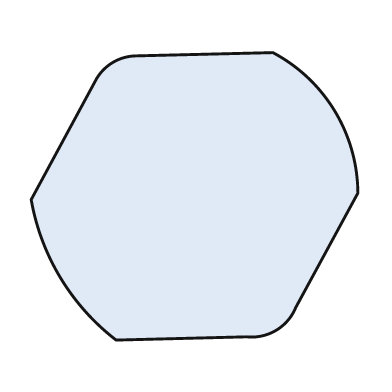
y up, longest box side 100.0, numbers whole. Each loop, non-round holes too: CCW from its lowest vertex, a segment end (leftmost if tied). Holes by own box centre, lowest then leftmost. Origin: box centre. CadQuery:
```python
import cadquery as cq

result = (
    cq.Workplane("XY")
    .moveTo(-24.0, -44.0)
    .lineTo(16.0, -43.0)
    .threePointArc((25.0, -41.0), (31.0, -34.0))
    .lineTo(50.0, 1.0)
    .threePointArc((43.0, 26.0), (24.0, 44.0))
    .lineTo(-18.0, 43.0)
    .threePointArc((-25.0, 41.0), (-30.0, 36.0))
    .lineTo(-50.0, -1.0)
    .threePointArc((-41.0, -25.0), (-24.0, -44.0))
    .close()
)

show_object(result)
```